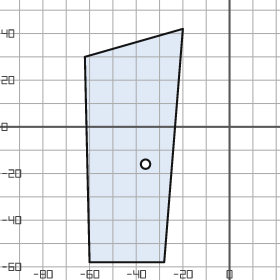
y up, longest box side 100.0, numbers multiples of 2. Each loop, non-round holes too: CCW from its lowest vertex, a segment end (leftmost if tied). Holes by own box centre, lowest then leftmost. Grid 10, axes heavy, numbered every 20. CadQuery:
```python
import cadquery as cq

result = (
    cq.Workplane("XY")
    .moveTo(-60.0, -58.0)
    .lineTo(-28.0, -58.0)
    .lineTo(-20.0, 42.0)
    .lineTo(-62.0, 30.0)
    .close()
    .moveTo(-36.0, -16.0)
    .circle(2.0)
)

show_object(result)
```